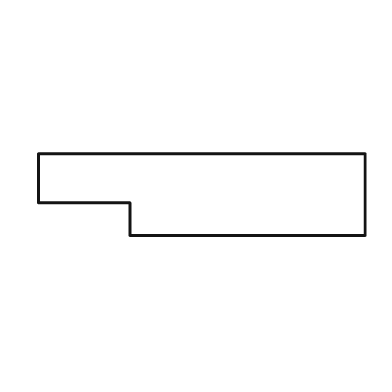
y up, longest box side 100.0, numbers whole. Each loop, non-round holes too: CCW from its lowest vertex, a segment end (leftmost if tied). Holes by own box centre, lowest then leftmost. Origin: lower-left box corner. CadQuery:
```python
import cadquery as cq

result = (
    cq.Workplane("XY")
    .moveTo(28.0, 0.0)
    .lineTo(100.0, 0.0)
    .lineTo(100.0, 25.0)
    .lineTo(0.0, 25.0)
    .lineTo(0.0, 10.0)
    .lineTo(28.0, 10.0)
    .close()
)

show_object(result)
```